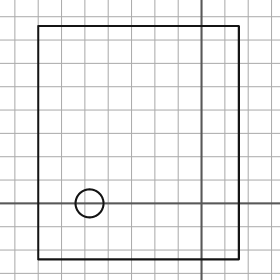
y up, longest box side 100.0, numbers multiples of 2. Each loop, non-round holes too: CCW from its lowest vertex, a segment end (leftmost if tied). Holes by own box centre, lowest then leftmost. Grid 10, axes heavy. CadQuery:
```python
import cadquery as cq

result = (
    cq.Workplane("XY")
    .moveTo(-70.0, -24.0)
    .lineTo(16.0, -24.0)
    .lineTo(16.0, 76.0)
    .lineTo(-70.0, 76.0)
    .close()
    .moveTo(-48.0, 0.0)
    .circle(6.0)
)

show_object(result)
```